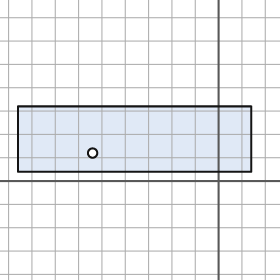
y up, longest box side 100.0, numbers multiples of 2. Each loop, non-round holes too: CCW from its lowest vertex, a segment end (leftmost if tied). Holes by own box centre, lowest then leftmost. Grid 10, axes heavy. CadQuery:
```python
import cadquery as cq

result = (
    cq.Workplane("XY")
    .moveTo(-86.0, 4.0)
    .lineTo(14.0, 4.0)
    .lineTo(14.0, 32.0)
    .lineTo(-86.0, 32.0)
    .close()
    .moveTo(-54.0, 12.0)
    .circle(2.0)
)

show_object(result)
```